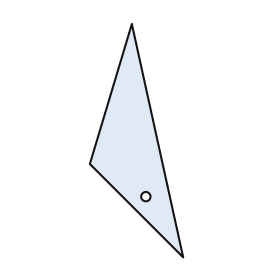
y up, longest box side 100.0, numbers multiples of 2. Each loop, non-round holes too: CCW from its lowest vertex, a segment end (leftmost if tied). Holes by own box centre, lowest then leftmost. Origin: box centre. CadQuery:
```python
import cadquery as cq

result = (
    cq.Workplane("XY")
    .moveTo(20.0, -50.0)
    .lineTo(-2.0, 50.0)
    .lineTo(-20.0, -10.0)
    .close()
    .moveTo(4.0, -24.0)
    .circle(2.0)
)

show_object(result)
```